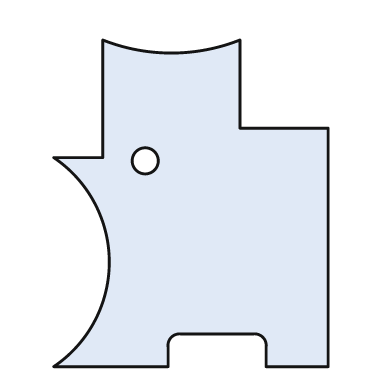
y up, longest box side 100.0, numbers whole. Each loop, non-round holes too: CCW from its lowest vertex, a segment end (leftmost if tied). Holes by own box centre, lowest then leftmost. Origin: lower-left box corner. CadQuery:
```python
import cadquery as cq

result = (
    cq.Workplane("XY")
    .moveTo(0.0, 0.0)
    .lineTo(35.0, 0.0)
    .lineTo(35.0, 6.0)
    .threePointArc((36.0, 9.0), (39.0, 10.0))
    .lineTo(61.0, 10.0)
    .threePointArc((64.0, 9.0), (65.0, 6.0))
    .lineTo(65.0, 0.0)
    .lineTo(84.0, 0.0)
    .lineTo(84.0, 73.0)
    .lineTo(57.0, 73.0)
    .lineTo(57.0, 100.0)
    .threePointArc((36.0, 96.0), (15.0, 100.0))
    .lineTo(15.0, 64.0)
    .lineTo(0.0, 64.0)
    .threePointArc((17.0, 32.0), (0.0, 0.0))
    .close()
    .moveTo(28.0, 63.0)
    .circle(4.0)
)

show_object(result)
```